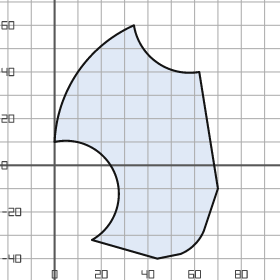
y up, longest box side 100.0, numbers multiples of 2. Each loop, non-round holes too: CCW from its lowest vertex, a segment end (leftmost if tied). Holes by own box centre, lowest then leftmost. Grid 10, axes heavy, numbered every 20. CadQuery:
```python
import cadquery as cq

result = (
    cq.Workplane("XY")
    .moveTo(44.0, -40.0)
    .lineTo(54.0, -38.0)
    .threePointArc((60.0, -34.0), (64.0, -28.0))
    .lineTo(70.0, -10.0)
    .lineTo(62.0, 40.0)
    .threePointArc((44.0, 44.0), (34.0, 60.0))
    .threePointArc((10.0, 40.0), (0.0, 10.0))
    .threePointArc((26.0, -4.0), (16.0, -32.0))
    .close()
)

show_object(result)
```